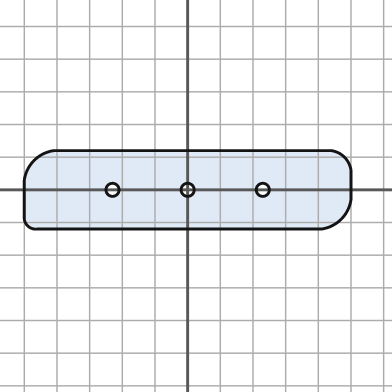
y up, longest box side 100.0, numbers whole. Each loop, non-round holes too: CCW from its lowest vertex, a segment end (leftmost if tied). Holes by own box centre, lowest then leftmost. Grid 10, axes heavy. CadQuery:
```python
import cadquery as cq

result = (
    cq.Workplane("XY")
    .moveTo(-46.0, -12.0)
    .lineTo(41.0, -12.0)
    .threePointArc((47.0, -9.0), (50.0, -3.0))
    .lineTo(50.0, 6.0)
    .threePointArc((48.0, 10.0), (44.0, 12.0))
    .lineTo(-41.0, 12.0)
    .threePointArc((-47.0, 9.0), (-50.0, 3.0))
    .lineTo(-50.0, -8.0)
    .threePointArc((-49.0, -11.0), (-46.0, -12.0))
    .close()
    .moveTo(-23.0, 0.0)
    .circle(2.0)
    .moveTo(0.0, 0.0)
    .circle(2.0)
    .moveTo(23.0, 0.0)
    .circle(2.0)
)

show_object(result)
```